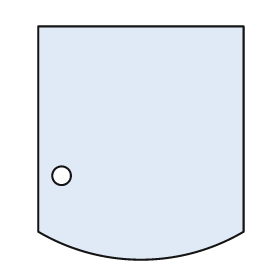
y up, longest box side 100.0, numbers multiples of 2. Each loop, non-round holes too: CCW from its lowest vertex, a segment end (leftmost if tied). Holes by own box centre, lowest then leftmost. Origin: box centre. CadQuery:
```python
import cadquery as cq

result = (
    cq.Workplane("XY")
    .moveTo(-44.0, -38.0)
    .threePointArc((0.0, -50.0), (44.0, -38.0))
    .lineTo(44.0, 50.0)
    .lineTo(-44.0, 50.0)
    .close()
    .moveTo(-34.0, -14.0)
    .circle(4.0)
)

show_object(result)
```